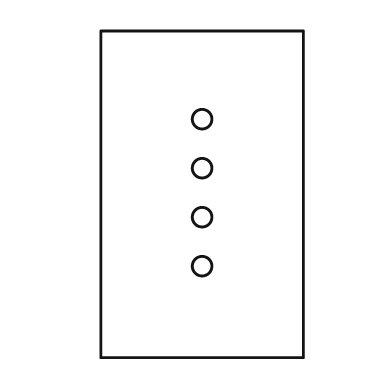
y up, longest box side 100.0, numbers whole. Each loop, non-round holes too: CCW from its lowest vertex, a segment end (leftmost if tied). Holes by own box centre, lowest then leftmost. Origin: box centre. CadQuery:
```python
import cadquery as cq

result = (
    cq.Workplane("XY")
    .moveTo(-31.0, -50.0)
    .lineTo(31.0, -50.0)
    .lineTo(31.0, 50.0)
    .lineTo(-31.0, 50.0)
    .close()
    .moveTo(0.0, -22.0)
    .circle(3.0)
    .moveTo(0.0, -7.0)
    .circle(3.0)
    .moveTo(0.0, 8.0)
    .circle(3.0)
    .moveTo(0.0, 23.0)
    .circle(3.0)
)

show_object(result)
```